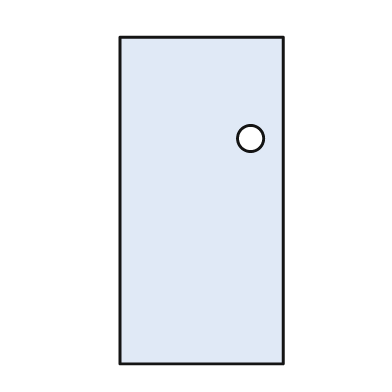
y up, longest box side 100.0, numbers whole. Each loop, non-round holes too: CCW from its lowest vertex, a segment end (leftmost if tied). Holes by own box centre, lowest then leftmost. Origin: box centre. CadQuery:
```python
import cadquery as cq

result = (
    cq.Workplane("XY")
    .moveTo(-25.0, -50.0)
    .lineTo(25.0, -50.0)
    .lineTo(25.0, 50.0)
    .lineTo(-25.0, 50.0)
    .close()
    .moveTo(15.0, 19.0)
    .circle(4.0)
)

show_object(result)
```